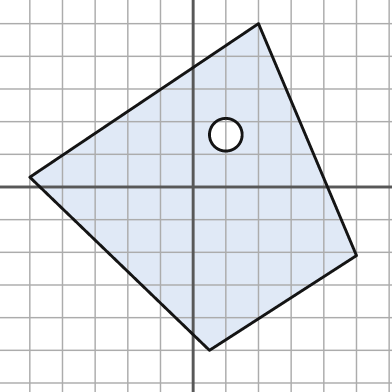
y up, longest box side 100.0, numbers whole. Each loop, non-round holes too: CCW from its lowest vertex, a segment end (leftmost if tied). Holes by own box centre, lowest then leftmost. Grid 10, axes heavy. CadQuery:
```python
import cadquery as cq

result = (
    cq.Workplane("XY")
    .moveTo(5.0, -50.0)
    .lineTo(50.0, -21.0)
    .lineTo(20.0, 50.0)
    .lineTo(-50.0, 3.0)
    .close()
    .moveTo(10.0, 16.0)
    .circle(5.0)
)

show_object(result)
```